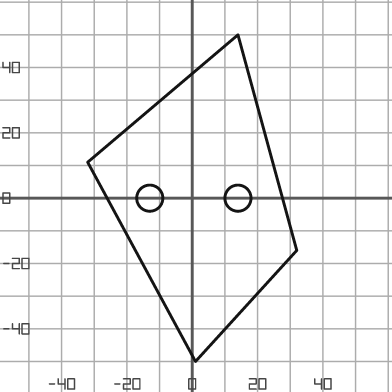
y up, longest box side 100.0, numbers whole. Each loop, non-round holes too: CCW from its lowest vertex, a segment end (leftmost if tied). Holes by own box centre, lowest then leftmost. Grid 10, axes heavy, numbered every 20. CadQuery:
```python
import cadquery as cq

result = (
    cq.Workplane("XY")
    .moveTo(1.0, -50.0)
    .lineTo(32.0, -16.0)
    .lineTo(14.0, 50.0)
    .lineTo(-32.0, 11.0)
    .close()
    .moveTo(-13.0, 0.0)
    .circle(4.0)
    .moveTo(14.0, 0.0)
    .circle(4.0)
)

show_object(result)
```